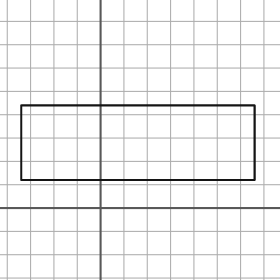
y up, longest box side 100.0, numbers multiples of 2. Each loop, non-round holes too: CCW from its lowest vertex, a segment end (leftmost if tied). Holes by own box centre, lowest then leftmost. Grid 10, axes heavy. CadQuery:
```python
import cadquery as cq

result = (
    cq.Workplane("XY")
    .moveTo(-34.0, 12.0)
    .lineTo(66.0, 12.0)
    .lineTo(66.0, 44.0)
    .lineTo(-34.0, 44.0)
    .close()
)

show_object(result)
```